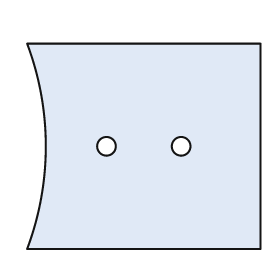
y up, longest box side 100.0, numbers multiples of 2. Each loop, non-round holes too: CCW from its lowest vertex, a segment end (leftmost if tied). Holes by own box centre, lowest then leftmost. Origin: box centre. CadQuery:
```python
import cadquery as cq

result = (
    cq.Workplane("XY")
    .moveTo(-50.0, -44.0)
    .lineTo(50.0, -44.0)
    .lineTo(50.0, 44.0)
    .lineTo(-50.0, 44.0)
    .threePointArc((-42.0, 0.0), (-50.0, -44.0))
    .close()
    .moveTo(-16.0, 0.0)
    .circle(4.0)
    .moveTo(16.0, 0.0)
    .circle(4.0)
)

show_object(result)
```